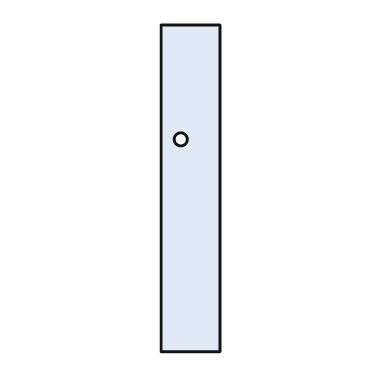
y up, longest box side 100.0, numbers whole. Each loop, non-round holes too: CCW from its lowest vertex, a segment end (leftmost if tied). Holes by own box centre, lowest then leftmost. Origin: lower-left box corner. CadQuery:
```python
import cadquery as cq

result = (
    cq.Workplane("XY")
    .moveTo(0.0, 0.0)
    .lineTo(18.0, 0.0)
    .lineTo(18.0, 100.0)
    .lineTo(0.0, 100.0)
    .close()
    .moveTo(6.0, 65.0)
    .circle(2.0)
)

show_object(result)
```